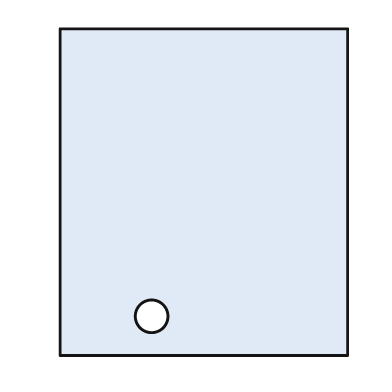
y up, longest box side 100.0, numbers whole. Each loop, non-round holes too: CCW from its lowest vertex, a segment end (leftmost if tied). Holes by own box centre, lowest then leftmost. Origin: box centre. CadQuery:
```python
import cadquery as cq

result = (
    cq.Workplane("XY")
    .moveTo(-44.0, -50.0)
    .lineTo(44.0, -50.0)
    .lineTo(44.0, 50.0)
    .lineTo(-44.0, 50.0)
    .close()
    .moveTo(-16.0, -38.0)
    .circle(5.0)
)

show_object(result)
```